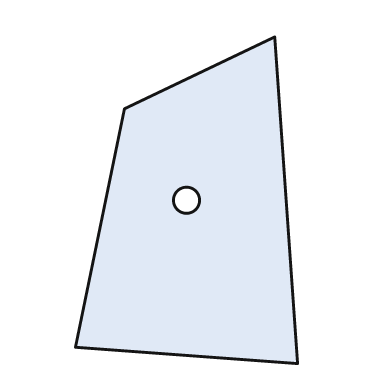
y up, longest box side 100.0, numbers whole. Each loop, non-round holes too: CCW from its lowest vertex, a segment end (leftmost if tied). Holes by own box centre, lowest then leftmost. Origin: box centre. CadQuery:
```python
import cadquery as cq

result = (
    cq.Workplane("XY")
    .moveTo(34.0, -50.0)
    .lineTo(27.0, 50.0)
    .lineTo(-19.0, 28.0)
    .lineTo(-34.0, -45.0)
    .close()
    .moveTo(0.0, 0.0)
    .circle(4.0)
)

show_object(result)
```